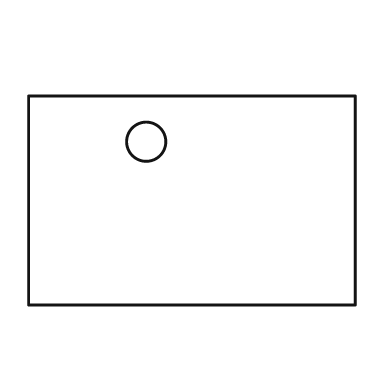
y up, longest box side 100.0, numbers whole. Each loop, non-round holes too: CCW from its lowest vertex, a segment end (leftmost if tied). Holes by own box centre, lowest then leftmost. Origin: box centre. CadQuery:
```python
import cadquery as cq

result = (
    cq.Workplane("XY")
    .moveTo(-50.0, -32.0)
    .lineTo(50.0, -32.0)
    .lineTo(50.0, 32.0)
    .lineTo(-50.0, 32.0)
    .close()
    .moveTo(-14.0, 18.0)
    .circle(6.0)
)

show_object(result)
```